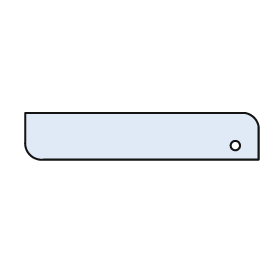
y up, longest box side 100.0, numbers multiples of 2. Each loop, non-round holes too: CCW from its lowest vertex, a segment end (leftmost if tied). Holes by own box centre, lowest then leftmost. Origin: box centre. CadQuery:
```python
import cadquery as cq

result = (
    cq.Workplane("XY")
    .moveTo(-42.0, -10.0)
    .lineTo(50.0, -10.0)
    .lineTo(50.0, 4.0)
    .threePointArc((48.0, 8.0), (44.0, 10.0))
    .lineTo(-50.0, 10.0)
    .lineTo(-50.0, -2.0)
    .threePointArc((-48.0, -8.0), (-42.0, -10.0))
    .close()
    .moveTo(40.0, -4.0)
    .circle(2.0)
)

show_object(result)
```